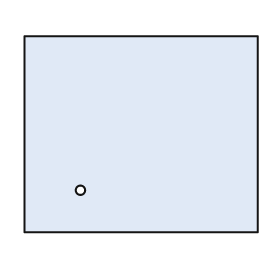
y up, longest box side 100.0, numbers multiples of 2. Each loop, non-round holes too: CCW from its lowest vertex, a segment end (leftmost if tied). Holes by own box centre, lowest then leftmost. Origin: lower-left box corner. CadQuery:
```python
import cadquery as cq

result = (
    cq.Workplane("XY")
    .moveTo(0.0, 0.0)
    .lineTo(100.0, 0.0)
    .lineTo(100.0, 84.0)
    .lineTo(0.0, 84.0)
    .close()
    .moveTo(24.0, 18.0)
    .circle(2.0)
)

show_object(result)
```